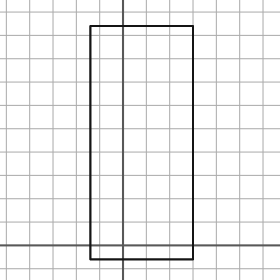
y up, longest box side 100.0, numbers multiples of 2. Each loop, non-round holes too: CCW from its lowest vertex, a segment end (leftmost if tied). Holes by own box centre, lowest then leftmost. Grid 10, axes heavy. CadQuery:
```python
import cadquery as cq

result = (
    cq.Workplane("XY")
    .moveTo(-14.0, -6.0)
    .lineTo(30.0, -6.0)
    .lineTo(30.0, 94.0)
    .lineTo(-14.0, 94.0)
    .close()
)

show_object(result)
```